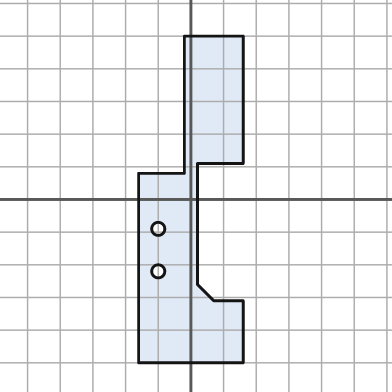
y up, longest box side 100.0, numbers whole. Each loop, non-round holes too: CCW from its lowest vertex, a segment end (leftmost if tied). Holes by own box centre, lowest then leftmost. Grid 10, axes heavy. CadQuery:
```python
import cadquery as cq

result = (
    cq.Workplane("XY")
    .moveTo(-16.0, -50.0)
    .lineTo(16.0, -50.0)
    .lineTo(16.0, -31.0)
    .lineTo(7.0, -31.0)
    .lineTo(2.0, -26.0)
    .lineTo(2.0, 11.0)
    .lineTo(16.0, 11.0)
    .lineTo(16.0, 50.0)
    .lineTo(-2.0, 50.0)
    .lineTo(-2.0, 8.0)
    .lineTo(-16.0, 8.0)
    .close()
    .moveTo(-10.0, -22.0)
    .circle(2.0)
    .moveTo(-10.0, -9.0)
    .circle(2.0)
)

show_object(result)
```